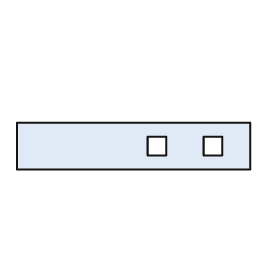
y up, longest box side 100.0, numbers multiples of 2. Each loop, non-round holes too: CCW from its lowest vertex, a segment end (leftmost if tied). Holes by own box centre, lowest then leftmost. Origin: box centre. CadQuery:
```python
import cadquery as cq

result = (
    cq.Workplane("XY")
    .moveTo(-50.0, -10.0)
    .lineTo(50.0, -10.0)
    .lineTo(50.0, 10.0)
    .lineTo(-50.0, 10.0)
    .close()
    .moveTo(6.0, -4.0)
    .lineTo(14.0, -4.0)
    .lineTo(14.0, 4.0)
    .lineTo(6.0, 4.0)
    .close()
    .moveTo(30.0, -4.0)
    .lineTo(38.0, -4.0)
    .lineTo(38.0, 4.0)
    .lineTo(30.0, 4.0)
    .close()
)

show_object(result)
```